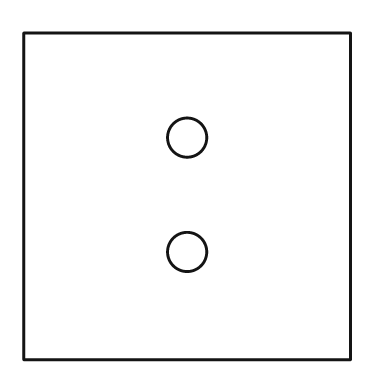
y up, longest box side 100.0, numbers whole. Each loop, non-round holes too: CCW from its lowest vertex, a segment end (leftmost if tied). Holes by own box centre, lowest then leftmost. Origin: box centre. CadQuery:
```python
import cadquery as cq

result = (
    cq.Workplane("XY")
    .moveTo(-50.0, -50.0)
    .lineTo(50.0, -50.0)
    .lineTo(50.0, 50.0)
    .lineTo(-50.0, 50.0)
    .close()
    .moveTo(0.0, -17.0)
    .circle(6.0)
    .moveTo(0.0, 18.0)
    .circle(6.0)
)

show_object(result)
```